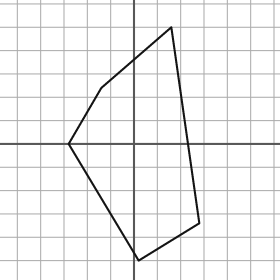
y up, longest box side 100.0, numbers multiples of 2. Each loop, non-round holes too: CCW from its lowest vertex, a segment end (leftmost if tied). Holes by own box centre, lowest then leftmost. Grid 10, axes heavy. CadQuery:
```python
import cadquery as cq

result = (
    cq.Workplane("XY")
    .moveTo(2.0, -50.0)
    .lineTo(28.0, -34.0)
    .lineTo(16.0, 50.0)
    .lineTo(-14.0, 24.0)
    .lineTo(-28.0, 0.0)
    .close()
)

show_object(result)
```